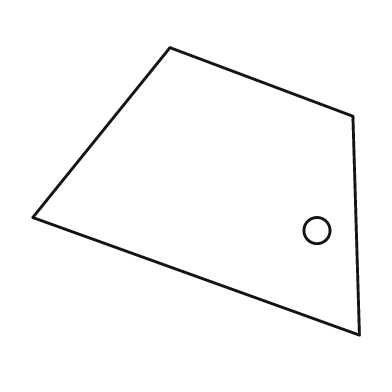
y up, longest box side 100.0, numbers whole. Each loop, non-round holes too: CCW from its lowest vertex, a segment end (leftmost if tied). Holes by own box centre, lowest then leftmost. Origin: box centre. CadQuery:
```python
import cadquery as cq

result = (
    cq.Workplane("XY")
    .moveTo(50.0, -44.0)
    .lineTo(48.0, 23.0)
    .lineTo(-8.0, 44.0)
    .lineTo(-50.0, -8.0)
    .close()
    .moveTo(37.0, -12.0)
    .circle(4.0)
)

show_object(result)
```